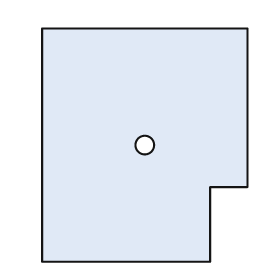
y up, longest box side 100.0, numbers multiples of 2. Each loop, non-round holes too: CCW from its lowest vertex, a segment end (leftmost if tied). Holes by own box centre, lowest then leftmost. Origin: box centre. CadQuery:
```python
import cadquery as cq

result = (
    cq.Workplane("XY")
    .moveTo(-44.0, -50.0)
    .lineTo(28.0, -50.0)
    .lineTo(28.0, -18.0)
    .lineTo(44.0, -18.0)
    .lineTo(44.0, 50.0)
    .lineTo(-44.0, 50.0)
    .close()
    .moveTo(0.0, 0.0)
    .circle(4.0)
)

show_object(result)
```